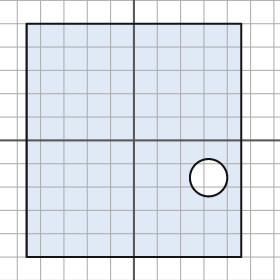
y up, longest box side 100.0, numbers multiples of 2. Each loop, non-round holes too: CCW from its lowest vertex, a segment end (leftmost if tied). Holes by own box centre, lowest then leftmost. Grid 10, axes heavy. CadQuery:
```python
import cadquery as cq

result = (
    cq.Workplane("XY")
    .moveTo(-46.0, -50.0)
    .lineTo(46.0, -50.0)
    .lineTo(46.0, 50.0)
    .lineTo(-46.0, 50.0)
    .close()
    .moveTo(32.0, -16.0)
    .circle(8.0)
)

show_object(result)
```